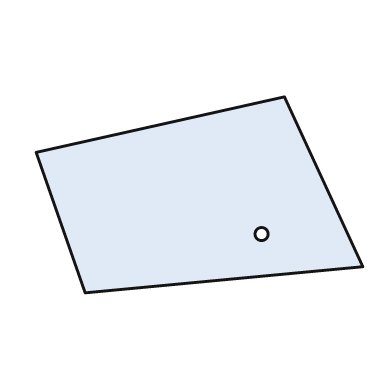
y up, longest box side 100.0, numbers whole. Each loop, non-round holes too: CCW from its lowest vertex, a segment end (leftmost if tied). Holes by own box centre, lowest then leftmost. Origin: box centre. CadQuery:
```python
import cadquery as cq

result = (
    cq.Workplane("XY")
    .moveTo(-35.0, -30.0)
    .lineTo(50.0, -22.0)
    .lineTo(26.0, 30.0)
    .lineTo(-50.0, 13.0)
    .close()
    .moveTo(19.0, -12.0)
    .circle(2.0)
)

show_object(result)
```